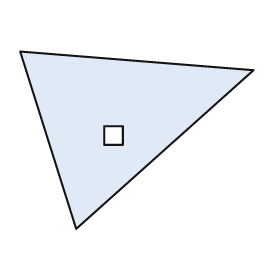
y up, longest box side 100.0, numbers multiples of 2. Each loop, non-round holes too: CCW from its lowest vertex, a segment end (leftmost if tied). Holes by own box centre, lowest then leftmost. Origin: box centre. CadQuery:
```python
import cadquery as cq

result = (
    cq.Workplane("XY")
    .moveTo(-26.0, -38.0)
    .lineTo(50.0, 30.0)
    .lineTo(-50.0, 38.0)
    .close()
    .moveTo(-14.0, -2.0)
    .lineTo(-6.0, -2.0)
    .lineTo(-6.0, 6.0)
    .lineTo(-14.0, 6.0)
    .close()
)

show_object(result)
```